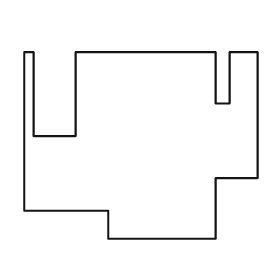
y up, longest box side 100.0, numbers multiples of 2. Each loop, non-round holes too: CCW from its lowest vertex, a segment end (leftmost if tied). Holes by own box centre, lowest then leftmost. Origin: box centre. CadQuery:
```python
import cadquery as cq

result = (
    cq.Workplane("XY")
    .moveTo(-14.0, -40.0)
    .lineTo(32.0, -40.0)
    .lineTo(32.0, -14.0)
    .lineTo(50.0, -14.0)
    .lineTo(50.0, 40.0)
    .lineTo(38.0, 40.0)
    .lineTo(38.0, 18.0)
    .lineTo(32.0, 18.0)
    .lineTo(32.0, 40.0)
    .lineTo(-28.0, 40.0)
    .lineTo(-28.0, 4.0)
    .lineTo(-46.0, 4.0)
    .lineTo(-46.0, 40.0)
    .lineTo(-50.0, 40.0)
    .lineTo(-50.0, -28.0)
    .lineTo(-14.0, -28.0)
    .close()
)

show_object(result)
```